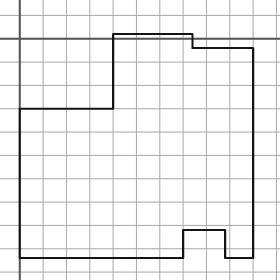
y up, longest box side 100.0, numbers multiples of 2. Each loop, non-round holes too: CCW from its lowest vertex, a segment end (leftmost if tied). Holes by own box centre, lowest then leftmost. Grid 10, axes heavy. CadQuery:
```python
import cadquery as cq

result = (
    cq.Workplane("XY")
    .moveTo(0.0, -94.0)
    .lineTo(70.0, -94.0)
    .lineTo(70.0, -82.0)
    .lineTo(88.0, -82.0)
    .lineTo(88.0, -94.0)
    .lineTo(100.0, -94.0)
    .lineTo(100.0, -4.0)
    .lineTo(74.0, -4.0)
    .lineTo(74.0, 2.0)
    .lineTo(40.0, 2.0)
    .lineTo(40.0, -30.0)
    .lineTo(0.0, -30.0)
    .close()
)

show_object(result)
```